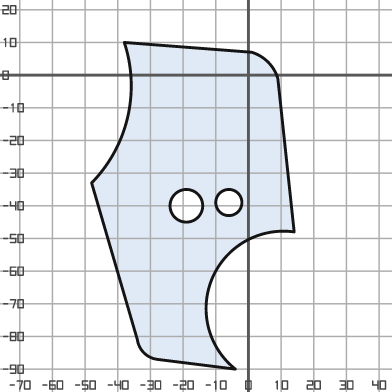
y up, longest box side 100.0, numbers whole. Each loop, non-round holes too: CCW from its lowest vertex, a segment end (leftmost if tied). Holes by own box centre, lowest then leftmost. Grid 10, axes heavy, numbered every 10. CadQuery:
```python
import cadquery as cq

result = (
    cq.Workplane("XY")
    .moveTo(-4.0, -90.0)
    .threePointArc((-11.0, -62.0), (14.0, -48.0))
    .lineTo(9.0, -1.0)
    .threePointArc((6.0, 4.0), (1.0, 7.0))
    .lineTo(-38.0, 10.0)
    .threePointArc((-37.0, -13.0), (-48.0, -33.0))
    .lineTo(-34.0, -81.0)
    .threePointArc((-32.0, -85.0), (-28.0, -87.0))
    .close()
    .moveTo(-19.0, -40.0)
    .circle(5.0)
    .moveTo(-6.0, -39.0)
    .circle(4.0)
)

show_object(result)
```